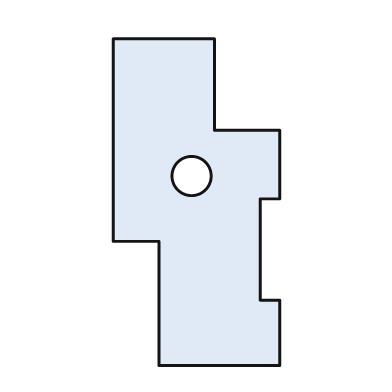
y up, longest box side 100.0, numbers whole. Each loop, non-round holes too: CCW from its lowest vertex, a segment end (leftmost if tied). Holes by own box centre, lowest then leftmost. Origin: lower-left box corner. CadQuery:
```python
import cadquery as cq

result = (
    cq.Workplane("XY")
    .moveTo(14.0, 0.0)
    .lineTo(51.0, 0.0)
    .lineTo(51.0, 20.0)
    .lineTo(45.0, 20.0)
    .lineTo(45.0, 51.0)
    .lineTo(51.0, 51.0)
    .lineTo(51.0, 72.0)
    .lineTo(31.0, 72.0)
    .lineTo(31.0, 100.0)
    .lineTo(0.0, 100.0)
    .lineTo(0.0, 38.0)
    .lineTo(14.0, 38.0)
    .close()
    .moveTo(24.0, 58.0)
    .circle(6.0)
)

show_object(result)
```